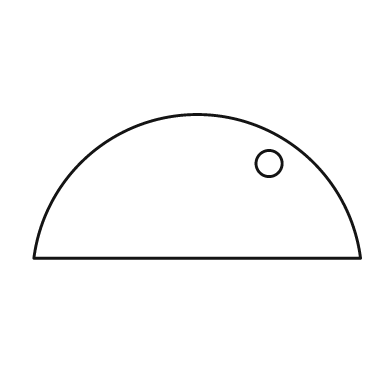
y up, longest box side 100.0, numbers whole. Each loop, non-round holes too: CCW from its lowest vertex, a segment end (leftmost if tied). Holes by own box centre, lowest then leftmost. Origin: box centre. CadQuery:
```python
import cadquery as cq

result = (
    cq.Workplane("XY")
    .moveTo(-50.0, -22.0)
    .lineTo(50.0, -22.0)
    .threePointArc((0.0, 22.0), (-50.0, -22.0))
    .close()
    .moveTo(22.0, 7.0)
    .circle(4.0)
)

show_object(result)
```